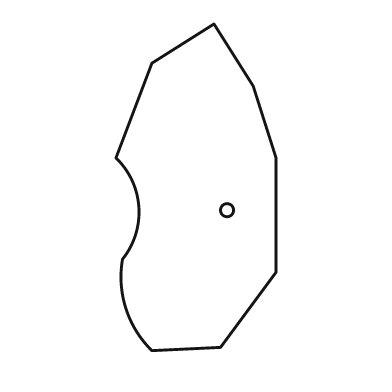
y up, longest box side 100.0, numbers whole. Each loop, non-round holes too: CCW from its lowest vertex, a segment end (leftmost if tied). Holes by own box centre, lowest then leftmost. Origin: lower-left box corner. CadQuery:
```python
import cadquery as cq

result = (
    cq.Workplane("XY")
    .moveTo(11.0, 0.0)
    .lineTo(32.0, 1.0)
    .lineTo(49.0, 24.0)
    .lineTo(49.0, 59.0)
    .lineTo(42.0, 81.0)
    .lineTo(30.0, 100.0)
    .lineTo(11.0, 88.0)
    .lineTo(0.0, 59.0)
    .threePointArc((7.0, 44.0), (2.0, 28.0))
    .threePointArc((3.0, 13.0), (11.0, 0.0))
    .close()
    .moveTo(34.0, 43.0)
    .circle(2.0)
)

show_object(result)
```